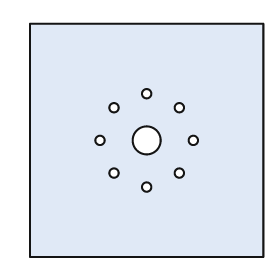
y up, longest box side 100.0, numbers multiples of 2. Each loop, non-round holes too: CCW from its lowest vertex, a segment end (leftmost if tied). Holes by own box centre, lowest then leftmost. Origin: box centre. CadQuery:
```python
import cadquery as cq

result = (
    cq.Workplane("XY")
    .moveTo(-50.0, -50.0)
    .lineTo(50.0, -50.0)
    .lineTo(50.0, 50.0)
    .lineTo(-50.0, 50.0)
    .close()
    .moveTo(0.0, -20.0)
    .circle(2.0)
    .moveTo(-14.0, -14.0)
    .circle(2.0)
    .moveTo(14.0, -14.0)
    .circle(2.0)
    .moveTo(-20.0, 0.0)
    .circle(2.0)
    .moveTo(0.0, 0.0)
    .circle(6.0)
    .moveTo(20.0, 0.0)
    .circle(2.0)
    .moveTo(-14.0, 14.0)
    .circle(2.0)
    .moveTo(14.0, 14.0)
    .circle(2.0)
    .moveTo(0.0, 20.0)
    .circle(2.0)
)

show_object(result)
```